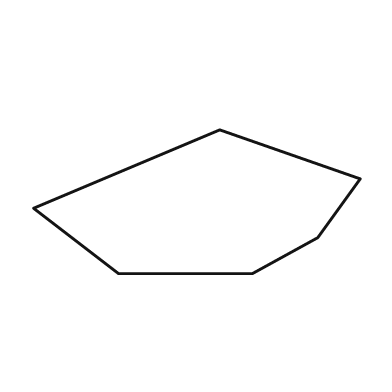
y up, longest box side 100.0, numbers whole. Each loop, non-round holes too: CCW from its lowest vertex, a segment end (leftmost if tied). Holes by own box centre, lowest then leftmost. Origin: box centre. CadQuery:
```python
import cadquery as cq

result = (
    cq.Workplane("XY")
    .moveTo(-24.0, -22.0)
    .lineTo(17.0, -22.0)
    .lineTo(37.0, -11.0)
    .lineTo(50.0, 7.0)
    .lineTo(7.0, 22.0)
    .lineTo(-50.0, -2.0)
    .close()
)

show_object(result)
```